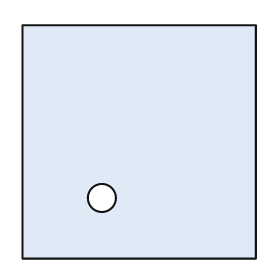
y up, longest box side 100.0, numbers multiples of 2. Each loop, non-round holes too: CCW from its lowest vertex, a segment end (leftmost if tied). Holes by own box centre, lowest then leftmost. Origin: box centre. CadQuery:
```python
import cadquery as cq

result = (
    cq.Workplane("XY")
    .moveTo(-50.0, -50.0)
    .lineTo(50.0, -50.0)
    .lineTo(50.0, 50.0)
    .lineTo(-50.0, 50.0)
    .close()
    .moveTo(-16.0, -24.0)
    .circle(6.0)
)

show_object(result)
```